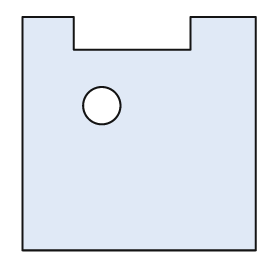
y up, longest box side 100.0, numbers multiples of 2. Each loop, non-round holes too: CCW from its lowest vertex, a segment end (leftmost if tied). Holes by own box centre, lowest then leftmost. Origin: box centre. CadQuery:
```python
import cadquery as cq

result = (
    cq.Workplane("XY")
    .moveTo(-50.0, -50.0)
    .lineTo(50.0, -50.0)
    .lineTo(50.0, 50.0)
    .lineTo(22.0, 50.0)
    .lineTo(22.0, 36.0)
    .lineTo(-28.0, 36.0)
    .lineTo(-28.0, 50.0)
    .lineTo(-50.0, 50.0)
    .close()
    .moveTo(-16.0, 12.0)
    .circle(8.0)
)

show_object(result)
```